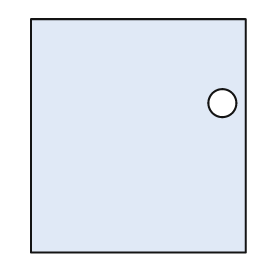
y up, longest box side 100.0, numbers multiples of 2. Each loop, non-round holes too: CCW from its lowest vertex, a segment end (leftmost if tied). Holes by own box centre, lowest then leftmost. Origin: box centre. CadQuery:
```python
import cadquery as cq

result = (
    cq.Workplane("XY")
    .moveTo(-46.0, -50.0)
    .lineTo(46.0, -50.0)
    .lineTo(46.0, 50.0)
    .lineTo(-46.0, 50.0)
    .close()
    .moveTo(36.0, 14.0)
    .circle(6.0)
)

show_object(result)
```